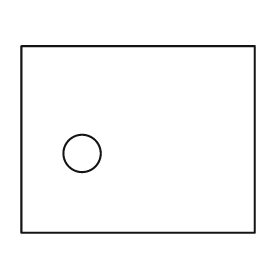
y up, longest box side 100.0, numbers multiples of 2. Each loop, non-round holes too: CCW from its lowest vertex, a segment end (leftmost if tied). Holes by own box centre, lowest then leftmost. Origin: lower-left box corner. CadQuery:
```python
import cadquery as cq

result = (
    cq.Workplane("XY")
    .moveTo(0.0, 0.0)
    .lineTo(100.0, 0.0)
    .lineTo(100.0, 80.0)
    .lineTo(0.0, 80.0)
    .close()
    .moveTo(26.0, 34.0)
    .circle(8.0)
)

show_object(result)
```